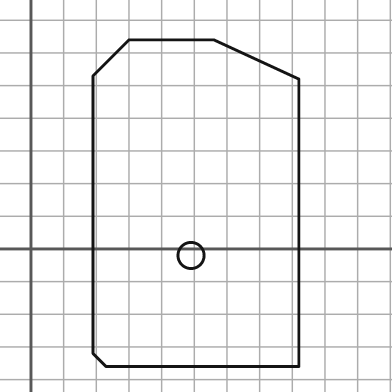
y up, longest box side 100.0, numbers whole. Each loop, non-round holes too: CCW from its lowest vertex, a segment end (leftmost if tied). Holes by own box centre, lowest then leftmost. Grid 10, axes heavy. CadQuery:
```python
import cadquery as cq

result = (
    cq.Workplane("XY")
    .moveTo(23.0, -36.0)
    .lineTo(82.0, -36.0)
    .lineTo(82.0, 52.0)
    .lineTo(56.0, 64.0)
    .lineTo(30.0, 64.0)
    .lineTo(19.0, 53.0)
    .lineTo(19.0, -32.0)
    .close()
    .moveTo(49.0, -2.0)
    .circle(4.0)
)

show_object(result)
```